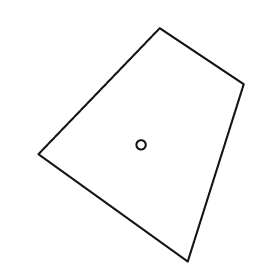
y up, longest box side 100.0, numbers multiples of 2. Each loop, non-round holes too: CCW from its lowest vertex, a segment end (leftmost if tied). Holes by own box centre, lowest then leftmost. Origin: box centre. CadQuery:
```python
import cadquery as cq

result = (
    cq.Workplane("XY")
    .moveTo(20.0, -50.0)
    .lineTo(44.0, 26.0)
    .lineTo(8.0, 50.0)
    .lineTo(-44.0, -4.0)
    .close()
    .moveTo(0.0, 0.0)
    .circle(2.0)
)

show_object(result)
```